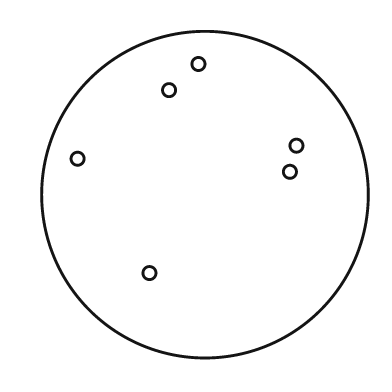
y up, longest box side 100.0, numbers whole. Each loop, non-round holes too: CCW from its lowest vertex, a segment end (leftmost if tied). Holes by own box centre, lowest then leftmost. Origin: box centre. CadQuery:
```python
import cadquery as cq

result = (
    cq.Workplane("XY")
    .moveTo(0.0, 0.0)
    .circle(50.0)
    .moveTo(-17.0, -24.0)
    .circle(2.0)
    .moveTo(26.0, 7.0)
    .circle(2.0)
    .moveTo(-39.0, 11.0)
    .circle(2.0)
    .moveTo(28.0, 15.0)
    .circle(2.0)
    .moveTo(-11.0, 32.0)
    .circle(2.0)
    .moveTo(-2.0, 40.0)
    .circle(2.0)
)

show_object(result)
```